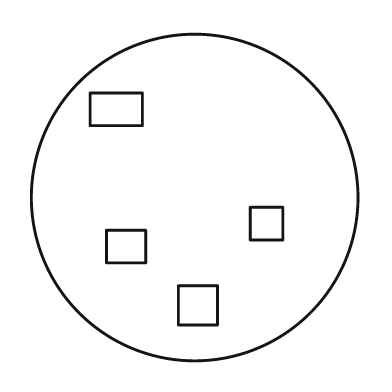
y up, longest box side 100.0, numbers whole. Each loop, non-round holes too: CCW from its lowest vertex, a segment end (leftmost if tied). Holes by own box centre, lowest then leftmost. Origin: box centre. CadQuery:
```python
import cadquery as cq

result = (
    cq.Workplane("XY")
    .moveTo(0.0, 0.0)
    .circle(50.0)
    .moveTo(-5.0, -39.0)
    .lineTo(7.0, -39.0)
    .lineTo(7.0, -27.0)
    .lineTo(-5.0, -27.0)
    .close()
    .moveTo(-27.0, -20.0)
    .lineTo(-15.0, -20.0)
    .lineTo(-15.0, -10.0)
    .lineTo(-27.0, -10.0)
    .close()
    .moveTo(17.0, -13.0)
    .lineTo(27.0, -13.0)
    .lineTo(27.0, -3.0)
    .lineTo(17.0, -3.0)
    .close()
    .moveTo(-32.0, 22.0)
    .lineTo(-16.0, 22.0)
    .lineTo(-16.0, 32.0)
    .lineTo(-32.0, 32.0)
    .close()
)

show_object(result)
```